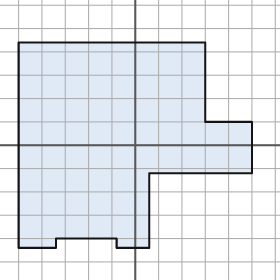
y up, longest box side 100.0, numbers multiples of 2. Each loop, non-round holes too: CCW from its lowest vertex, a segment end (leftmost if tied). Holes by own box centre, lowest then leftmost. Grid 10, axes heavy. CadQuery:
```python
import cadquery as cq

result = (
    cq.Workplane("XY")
    .moveTo(-50.0, -44.0)
    .lineTo(-34.0, -44.0)
    .lineTo(-34.0, -40.0)
    .lineTo(-8.0, -40.0)
    .lineTo(-8.0, -44.0)
    .lineTo(6.0, -44.0)
    .lineTo(6.0, -12.0)
    .lineTo(50.0, -12.0)
    .lineTo(50.0, 10.0)
    .lineTo(30.0, 10.0)
    .lineTo(30.0, 44.0)
    .lineTo(-50.0, 44.0)
    .close()
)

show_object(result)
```